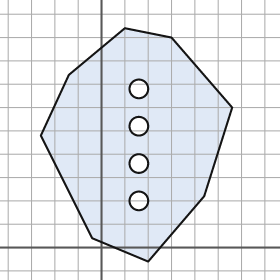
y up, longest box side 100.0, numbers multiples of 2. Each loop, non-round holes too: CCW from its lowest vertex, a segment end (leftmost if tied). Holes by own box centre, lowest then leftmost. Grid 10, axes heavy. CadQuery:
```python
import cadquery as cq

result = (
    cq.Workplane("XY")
    .moveTo(20.0, -6.0)
    .lineTo(44.0, 22.0)
    .lineTo(56.0, 60.0)
    .lineTo(30.0, 90.0)
    .lineTo(10.0, 94.0)
    .lineTo(-14.0, 74.0)
    .lineTo(-26.0, 48.0)
    .lineTo(-4.0, 4.0)
    .close()
    .moveTo(16.0, 20.0)
    .circle(4.0)
    .moveTo(16.0, 36.0)
    .circle(4.0)
    .moveTo(16.0, 52.0)
    .circle(4.0)
    .moveTo(16.0, 68.0)
    .circle(4.0)
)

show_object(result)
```